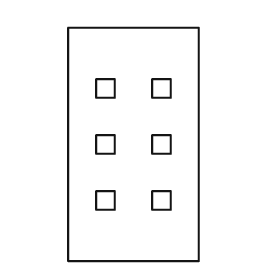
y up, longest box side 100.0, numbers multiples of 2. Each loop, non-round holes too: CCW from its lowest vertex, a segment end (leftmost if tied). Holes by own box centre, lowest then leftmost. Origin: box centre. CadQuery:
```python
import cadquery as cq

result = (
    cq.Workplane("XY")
    .moveTo(-28.0, -50.0)
    .lineTo(28.0, -50.0)
    .lineTo(28.0, 50.0)
    .lineTo(-28.0, 50.0)
    .close()
    .moveTo(-16.0, -28.0)
    .lineTo(-8.0, -28.0)
    .lineTo(-8.0, -20.0)
    .lineTo(-16.0, -20.0)
    .close()
    .moveTo(8.0, -28.0)
    .lineTo(16.0, -28.0)
    .lineTo(16.0, -20.0)
    .lineTo(8.0, -20.0)
    .close()
    .moveTo(-16.0, -4.0)
    .lineTo(-8.0, -4.0)
    .lineTo(-8.0, 4.0)
    .lineTo(-16.0, 4.0)
    .close()
    .moveTo(8.0, -4.0)
    .lineTo(16.0, -4.0)
    .lineTo(16.0, 4.0)
    .lineTo(8.0, 4.0)
    .close()
    .moveTo(-16.0, 20.0)
    .lineTo(-8.0, 20.0)
    .lineTo(-8.0, 28.0)
    .lineTo(-16.0, 28.0)
    .close()
    .moveTo(8.0, 20.0)
    .lineTo(16.0, 20.0)
    .lineTo(16.0, 28.0)
    .lineTo(8.0, 28.0)
    .close()
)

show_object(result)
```